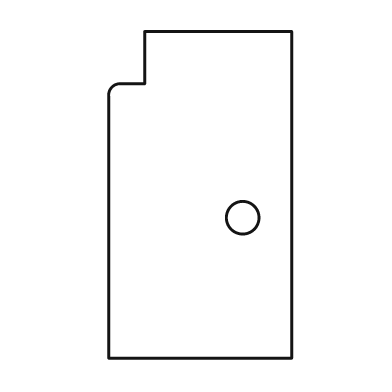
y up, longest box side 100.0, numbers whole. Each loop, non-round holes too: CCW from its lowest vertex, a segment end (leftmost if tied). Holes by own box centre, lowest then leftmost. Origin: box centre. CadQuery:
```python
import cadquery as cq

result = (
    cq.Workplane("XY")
    .moveTo(-28.0, -50.0)
    .lineTo(28.0, -50.0)
    .lineTo(28.0, 50.0)
    .lineTo(-17.0, 50.0)
    .lineTo(-17.0, 34.0)
    .lineTo(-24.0, 34.0)
    .threePointArc((-27.0, 33.0), (-28.0, 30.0))
    .close()
    .moveTo(13.0, -7.0)
    .circle(5.0)
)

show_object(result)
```